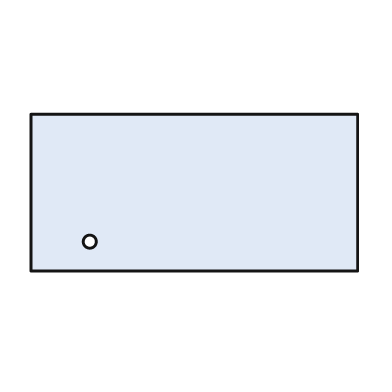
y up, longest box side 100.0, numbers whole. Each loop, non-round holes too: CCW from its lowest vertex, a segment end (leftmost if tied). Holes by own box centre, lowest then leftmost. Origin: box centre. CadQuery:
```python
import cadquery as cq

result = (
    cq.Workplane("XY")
    .moveTo(-50.0, -24.0)
    .lineTo(50.0, -24.0)
    .lineTo(50.0, 24.0)
    .lineTo(-50.0, 24.0)
    .close()
    .moveTo(-32.0, -15.0)
    .circle(2.0)
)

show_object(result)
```